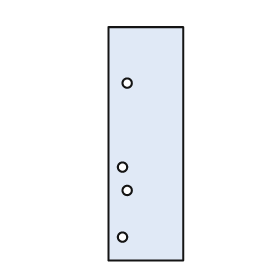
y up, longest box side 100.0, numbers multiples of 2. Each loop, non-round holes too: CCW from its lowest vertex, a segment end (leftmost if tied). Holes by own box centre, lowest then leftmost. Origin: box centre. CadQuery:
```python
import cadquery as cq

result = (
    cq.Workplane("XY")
    .moveTo(-16.0, -50.0)
    .lineTo(16.0, -50.0)
    .lineTo(16.0, 50.0)
    .lineTo(-16.0, 50.0)
    .close()
    .moveTo(-10.0, -40.0)
    .circle(2.0)
    .moveTo(-8.0, -20.0)
    .circle(2.0)
    .moveTo(-10.0, -10.0)
    .circle(2.0)
    .moveTo(-8.0, 26.0)
    .circle(2.0)
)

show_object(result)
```